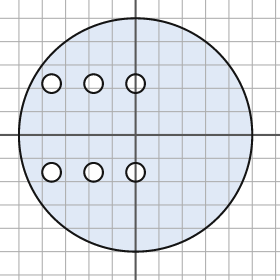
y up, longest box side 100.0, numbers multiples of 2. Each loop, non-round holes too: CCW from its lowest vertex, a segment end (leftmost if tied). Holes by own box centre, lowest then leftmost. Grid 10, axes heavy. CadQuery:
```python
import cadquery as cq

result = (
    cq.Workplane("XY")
    .moveTo(0.0, 0.0)
    .circle(50.0)
    .moveTo(-36.0, -16.0)
    .circle(4.0)
    .moveTo(-18.0, -16.0)
    .circle(4.0)
    .moveTo(0.0, -16.0)
    .circle(4.0)
    .moveTo(-36.0, 22.0)
    .circle(4.0)
    .moveTo(-18.0, 22.0)
    .circle(4.0)
    .moveTo(0.0, 22.0)
    .circle(4.0)
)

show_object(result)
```